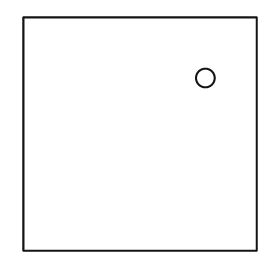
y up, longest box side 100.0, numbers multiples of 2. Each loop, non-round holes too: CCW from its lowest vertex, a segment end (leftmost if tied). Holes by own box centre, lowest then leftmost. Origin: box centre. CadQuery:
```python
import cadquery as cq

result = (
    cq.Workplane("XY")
    .moveTo(-50.0, -50.0)
    .lineTo(50.0, -50.0)
    .lineTo(50.0, 50.0)
    .lineTo(-50.0, 50.0)
    .close()
    .moveTo(28.0, 24.0)
    .circle(4.0)
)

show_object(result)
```